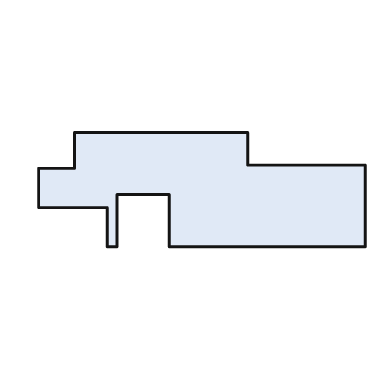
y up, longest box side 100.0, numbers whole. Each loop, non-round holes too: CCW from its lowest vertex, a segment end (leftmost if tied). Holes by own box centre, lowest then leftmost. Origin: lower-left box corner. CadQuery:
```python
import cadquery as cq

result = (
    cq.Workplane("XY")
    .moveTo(21.0, 0.0)
    .lineTo(24.0, 0.0)
    .lineTo(24.0, 16.0)
    .lineTo(40.0, 16.0)
    .lineTo(40.0, 0.0)
    .lineTo(100.0, 0.0)
    .lineTo(100.0, 25.0)
    .lineTo(64.0, 25.0)
    .lineTo(64.0, 35.0)
    .lineTo(11.0, 35.0)
    .lineTo(11.0, 24.0)
    .lineTo(0.0, 24.0)
    .lineTo(0.0, 12.0)
    .lineTo(21.0, 12.0)
    .close()
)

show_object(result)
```